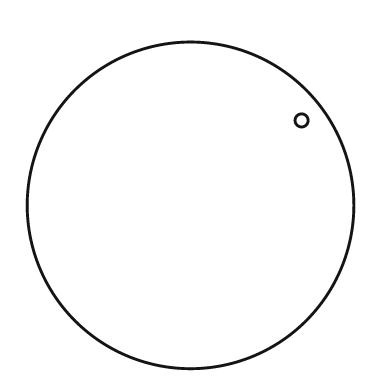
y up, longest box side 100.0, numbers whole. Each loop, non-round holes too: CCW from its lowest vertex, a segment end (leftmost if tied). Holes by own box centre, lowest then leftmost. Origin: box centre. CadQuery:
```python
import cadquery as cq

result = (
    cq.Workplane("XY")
    .moveTo(0.0, 0.0)
    .circle(50.0)
    .moveTo(34.0, 26.0)
    .circle(2.0)
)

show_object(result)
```